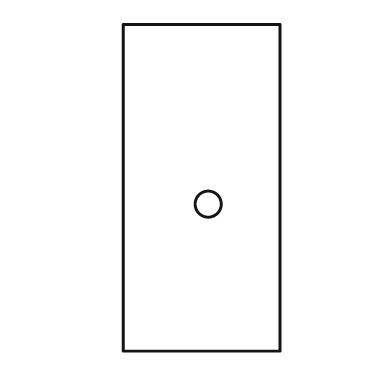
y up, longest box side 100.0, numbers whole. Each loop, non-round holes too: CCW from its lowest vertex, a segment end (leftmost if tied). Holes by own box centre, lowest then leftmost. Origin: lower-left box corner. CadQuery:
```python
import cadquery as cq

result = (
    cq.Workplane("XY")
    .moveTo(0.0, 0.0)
    .lineTo(48.0, 0.0)
    .lineTo(48.0, 100.0)
    .lineTo(0.0, 100.0)
    .close()
    .moveTo(26.0, 45.0)
    .circle(4.0)
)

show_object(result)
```